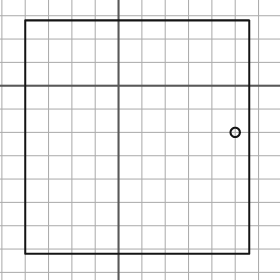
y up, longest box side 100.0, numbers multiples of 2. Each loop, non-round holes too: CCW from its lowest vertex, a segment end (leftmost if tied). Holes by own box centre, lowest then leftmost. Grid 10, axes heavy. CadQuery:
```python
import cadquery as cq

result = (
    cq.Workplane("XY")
    .moveTo(-40.0, -72.0)
    .lineTo(56.0, -72.0)
    .lineTo(56.0, 28.0)
    .lineTo(-40.0, 28.0)
    .close()
    .moveTo(50.0, -20.0)
    .circle(2.0)
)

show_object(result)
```